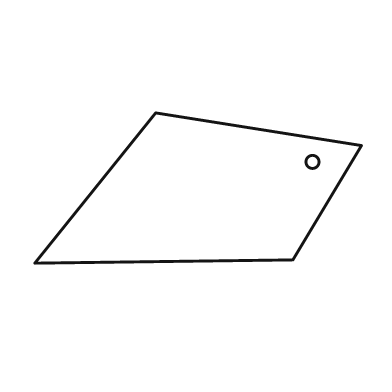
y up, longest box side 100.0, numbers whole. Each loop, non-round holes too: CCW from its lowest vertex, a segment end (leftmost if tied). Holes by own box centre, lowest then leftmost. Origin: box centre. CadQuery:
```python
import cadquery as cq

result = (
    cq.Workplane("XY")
    .moveTo(-50.0, -23.0)
    .lineTo(29.0, -22.0)
    .lineTo(50.0, 13.0)
    .lineTo(-13.0, 23.0)
    .close()
    .moveTo(35.0, 8.0)
    .circle(2.0)
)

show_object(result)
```